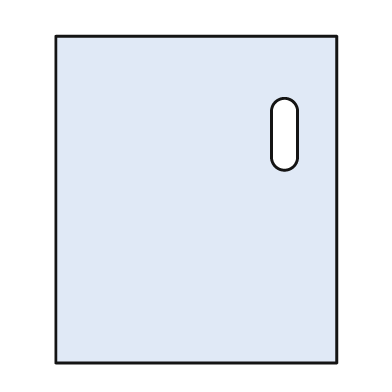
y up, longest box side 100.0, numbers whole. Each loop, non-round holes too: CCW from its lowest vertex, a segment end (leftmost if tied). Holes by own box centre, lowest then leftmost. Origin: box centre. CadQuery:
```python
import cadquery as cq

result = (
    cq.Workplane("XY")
    .moveTo(-43.0, -50.0)
    .lineTo(43.0, -50.0)
    .lineTo(43.0, 50.0)
    .lineTo(-43.0, 50.0)
    .close()
    .moveTo(23.0, 13.0)
    .threePointArc((27.0, 9.0), (31.0, 13.0))
    .lineTo(31.0, 27.0)
    .threePointArc((27.0, 31.0), (23.0, 27.0))
    .close()
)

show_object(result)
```